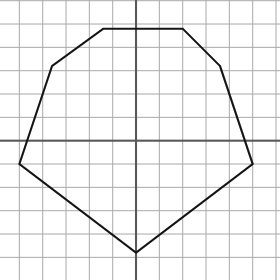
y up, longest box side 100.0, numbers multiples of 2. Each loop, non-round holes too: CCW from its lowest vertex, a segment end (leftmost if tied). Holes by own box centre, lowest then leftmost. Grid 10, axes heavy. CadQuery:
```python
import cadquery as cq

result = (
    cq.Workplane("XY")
    .moveTo(0.0, -48.0)
    .lineTo(50.0, -10.0)
    .lineTo(36.0, 32.0)
    .lineTo(20.0, 48.0)
    .lineTo(-14.0, 48.0)
    .lineTo(-36.0, 32.0)
    .lineTo(-50.0, -10.0)
    .close()
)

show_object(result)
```